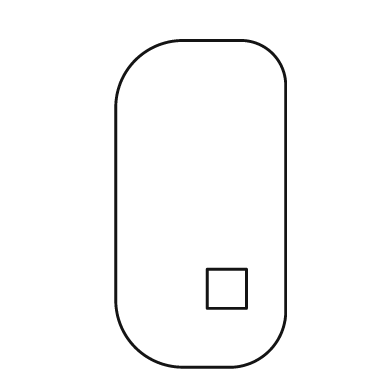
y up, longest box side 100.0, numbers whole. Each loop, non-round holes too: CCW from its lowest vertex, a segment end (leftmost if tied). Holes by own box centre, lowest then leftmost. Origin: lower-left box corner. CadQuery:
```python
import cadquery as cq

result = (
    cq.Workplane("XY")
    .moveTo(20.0, 0.0)
    .lineTo(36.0, 0.0)
    .threePointArc((47.0, 5.0), (52.0, 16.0))
    .lineTo(52.0, 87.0)
    .threePointArc((48.0, 96.0), (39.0, 100.0))
    .lineTo(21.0, 100.0)
    .threePointArc((6.0, 94.0), (0.0, 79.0))
    .lineTo(0.0, 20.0)
    .threePointArc((6.0, 6.0), (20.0, 0.0))
    .close()
    .moveTo(28.0, 18.0)
    .lineTo(40.0, 18.0)
    .lineTo(40.0, 30.0)
    .lineTo(28.0, 30.0)
    .close()
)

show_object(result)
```